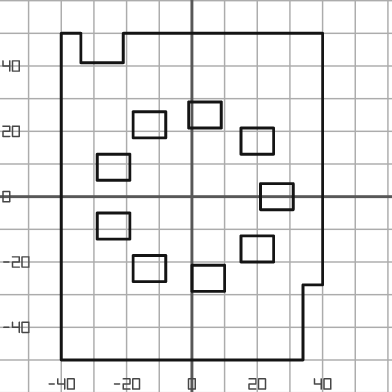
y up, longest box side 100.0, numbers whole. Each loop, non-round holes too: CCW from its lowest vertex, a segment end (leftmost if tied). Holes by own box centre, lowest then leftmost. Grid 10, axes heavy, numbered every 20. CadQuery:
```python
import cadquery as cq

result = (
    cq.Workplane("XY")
    .moveTo(-40.0, -50.0)
    .lineTo(34.0, -50.0)
    .lineTo(34.0, -27.0)
    .lineTo(40.0, -27.0)
    .lineTo(40.0, 50.0)
    .lineTo(-21.0, 50.0)
    .lineTo(-21.0, 41.0)
    .lineTo(-34.0, 41.0)
    .lineTo(-34.0, 50.0)
    .lineTo(-40.0, 50.0)
    .close()
    .moveTo(0.0, -29.0)
    .lineTo(10.0, -29.0)
    .lineTo(10.0, -21.0)
    .lineTo(0.0, -21.0)
    .close()
    .moveTo(-18.0, -26.0)
    .lineTo(-8.0, -26.0)
    .lineTo(-8.0, -18.0)
    .lineTo(-18.0, -18.0)
    .close()
    .moveTo(15.0, -20.0)
    .lineTo(25.0, -20.0)
    .lineTo(25.0, -12.0)
    .lineTo(15.0, -12.0)
    .close()
    .moveTo(-29.0, -13.0)
    .lineTo(-19.0, -13.0)
    .lineTo(-19.0, -5.0)
    .lineTo(-29.0, -5.0)
    .close()
    .moveTo(21.0, -4.0)
    .lineTo(31.0, -4.0)
    .lineTo(31.0, 4.0)
    .lineTo(21.0, 4.0)
    .close()
    .moveTo(-29.0, 5.0)
    .lineTo(-19.0, 5.0)
    .lineTo(-19.0, 13.0)
    .lineTo(-29.0, 13.0)
    .close()
    .moveTo(15.0, 13.0)
    .lineTo(25.0, 13.0)
    .lineTo(25.0, 21.0)
    .lineTo(15.0, 21.0)
    .close()
    .moveTo(-18.0, 18.0)
    .lineTo(-8.0, 18.0)
    .lineTo(-8.0, 26.0)
    .lineTo(-18.0, 26.0)
    .close()
    .moveTo(-1.0, 21.0)
    .lineTo(9.0, 21.0)
    .lineTo(9.0, 29.0)
    .lineTo(-1.0, 29.0)
    .close()
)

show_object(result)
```